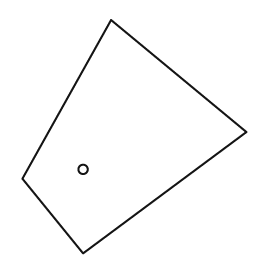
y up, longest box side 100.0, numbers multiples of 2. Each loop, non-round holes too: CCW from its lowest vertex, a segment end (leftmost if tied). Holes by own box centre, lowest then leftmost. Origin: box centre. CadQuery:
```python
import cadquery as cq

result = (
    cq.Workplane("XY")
    .moveTo(-22.0, -50.0)
    .lineTo(48.0, 2.0)
    .lineTo(-10.0, 50.0)
    .lineTo(-48.0, -18.0)
    .close()
    .moveTo(-22.0, -14.0)
    .circle(2.0)
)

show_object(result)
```